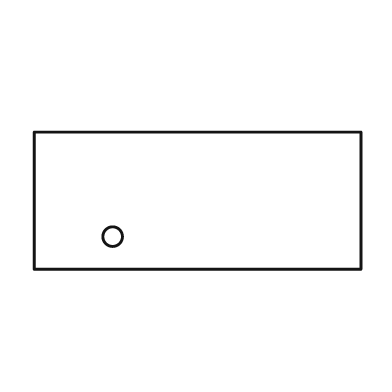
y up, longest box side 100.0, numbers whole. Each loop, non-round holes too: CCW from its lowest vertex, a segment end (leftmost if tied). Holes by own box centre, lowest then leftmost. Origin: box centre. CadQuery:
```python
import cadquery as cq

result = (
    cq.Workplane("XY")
    .moveTo(-50.0, -21.0)
    .lineTo(50.0, -21.0)
    .lineTo(50.0, 21.0)
    .lineTo(-50.0, 21.0)
    .close()
    .moveTo(-26.0, -11.0)
    .circle(3.0)
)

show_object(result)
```